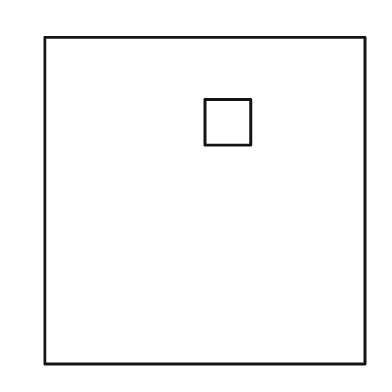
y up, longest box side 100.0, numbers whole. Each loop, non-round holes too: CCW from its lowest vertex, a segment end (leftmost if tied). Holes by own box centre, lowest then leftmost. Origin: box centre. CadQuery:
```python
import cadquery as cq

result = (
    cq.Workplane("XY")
    .moveTo(-49.0, -50.0)
    .lineTo(49.0, -50.0)
    .lineTo(49.0, 50.0)
    .lineTo(-49.0, 50.0)
    .close()
    .moveTo(0.0, 17.0)
    .lineTo(14.0, 17.0)
    .lineTo(14.0, 31.0)
    .lineTo(0.0, 31.0)
    .close()
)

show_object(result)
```